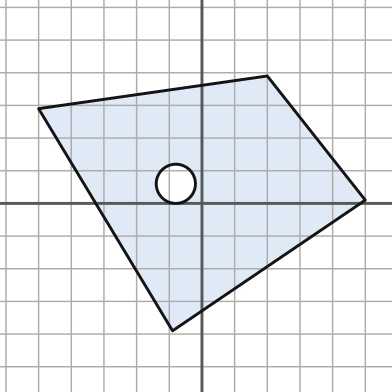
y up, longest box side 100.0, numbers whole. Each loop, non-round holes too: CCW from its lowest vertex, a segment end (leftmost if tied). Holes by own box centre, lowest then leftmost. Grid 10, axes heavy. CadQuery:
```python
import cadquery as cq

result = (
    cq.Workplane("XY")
    .moveTo(-9.0, -39.0)
    .lineTo(50.0, 1.0)
    .lineTo(20.0, 39.0)
    .lineTo(-50.0, 29.0)
    .close()
    .moveTo(-8.0, 6.0)
    .circle(6.0)
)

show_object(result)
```